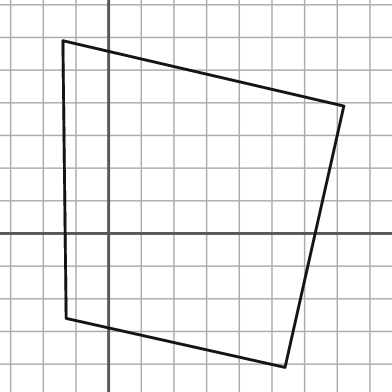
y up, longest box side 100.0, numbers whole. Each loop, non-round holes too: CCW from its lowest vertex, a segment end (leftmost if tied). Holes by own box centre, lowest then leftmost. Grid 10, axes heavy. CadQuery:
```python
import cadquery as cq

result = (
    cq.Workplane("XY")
    .moveTo(54.0, -41.0)
    .lineTo(72.0, 39.0)
    .lineTo(-14.0, 59.0)
    .lineTo(-13.0, -26.0)
    .close()
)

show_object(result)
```